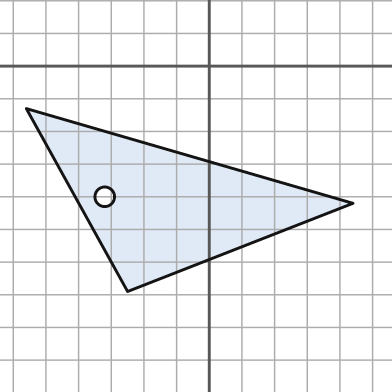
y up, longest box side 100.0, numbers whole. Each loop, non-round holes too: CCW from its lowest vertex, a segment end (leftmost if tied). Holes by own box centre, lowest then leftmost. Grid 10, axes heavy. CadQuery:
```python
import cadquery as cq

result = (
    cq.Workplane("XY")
    .moveTo(-25.0, -69.0)
    .lineTo(44.0, -42.0)
    .lineTo(-56.0, -13.0)
    .close()
    .moveTo(-32.0, -40.0)
    .circle(3.0)
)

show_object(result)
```